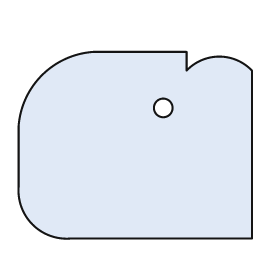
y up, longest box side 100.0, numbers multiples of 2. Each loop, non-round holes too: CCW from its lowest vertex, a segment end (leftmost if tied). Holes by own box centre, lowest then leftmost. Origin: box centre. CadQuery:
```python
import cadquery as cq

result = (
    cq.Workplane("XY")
    .moveTo(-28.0, -40.0)
    .lineTo(50.0, -40.0)
    .lineTo(50.0, 32.0)
    .threePointArc((36.0, 38.0), (22.0, 32.0))
    .lineTo(22.0, 40.0)
    .lineTo(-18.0, 40.0)
    .threePointArc((-40.0, 30.0), (-50.0, 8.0))
    .lineTo(-50.0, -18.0)
    .threePointArc((-44.0, -34.0), (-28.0, -40.0))
    .close()
    .moveTo(12.0, 16.0)
    .circle(4.0)
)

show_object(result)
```